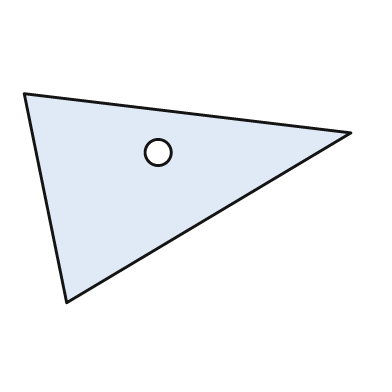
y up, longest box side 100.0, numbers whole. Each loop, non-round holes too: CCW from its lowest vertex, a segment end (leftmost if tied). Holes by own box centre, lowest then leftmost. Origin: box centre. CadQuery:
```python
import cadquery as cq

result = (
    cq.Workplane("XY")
    .moveTo(-37.0, -32.0)
    .lineTo(50.0, 20.0)
    .lineTo(-50.0, 32.0)
    .close()
    .moveTo(-9.0, 14.0)
    .circle(4.0)
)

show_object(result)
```